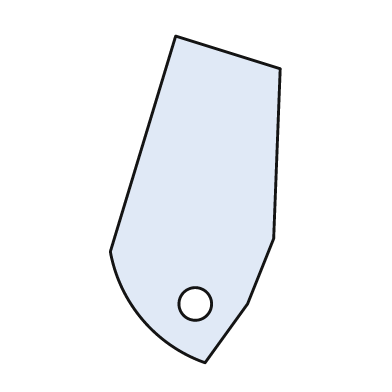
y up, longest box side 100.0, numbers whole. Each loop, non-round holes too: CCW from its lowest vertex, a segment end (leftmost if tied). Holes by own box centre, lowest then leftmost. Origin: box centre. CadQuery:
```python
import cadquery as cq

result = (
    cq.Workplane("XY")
    .moveTo(3.0, -50.0)
    .lineTo(16.0, -32.0)
    .lineTo(24.0, -12.0)
    .lineTo(26.0, 40.0)
    .lineTo(-6.0, 50.0)
    .lineTo(-26.0, -16.0)
    .threePointArc((-16.0, -37.0), (3.0, -50.0))
    .close()
    .moveTo(0.0, -32.0)
    .circle(5.0)
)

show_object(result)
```